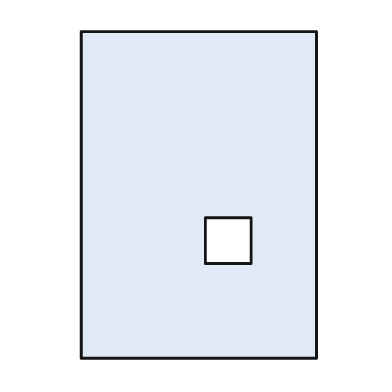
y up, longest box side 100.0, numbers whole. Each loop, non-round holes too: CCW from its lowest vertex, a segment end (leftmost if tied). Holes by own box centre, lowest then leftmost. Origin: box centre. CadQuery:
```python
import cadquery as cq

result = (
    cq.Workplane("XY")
    .moveTo(-36.0, -50.0)
    .lineTo(36.0, -50.0)
    .lineTo(36.0, 50.0)
    .lineTo(-36.0, 50.0)
    .close()
    .moveTo(2.0, -21.0)
    .lineTo(16.0, -21.0)
    .lineTo(16.0, -7.0)
    .lineTo(2.0, -7.0)
    .close()
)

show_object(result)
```